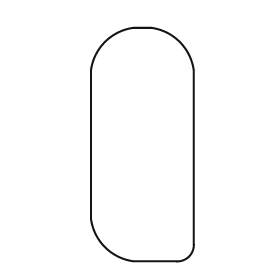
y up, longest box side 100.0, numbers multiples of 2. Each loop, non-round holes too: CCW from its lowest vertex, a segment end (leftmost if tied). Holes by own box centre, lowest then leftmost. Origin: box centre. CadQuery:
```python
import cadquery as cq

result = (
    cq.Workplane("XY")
    .moveTo(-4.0, -50.0)
    .lineTo(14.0, -50.0)
    .threePointArc((20.0, -48.0), (22.0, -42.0))
    .lineTo(22.0, 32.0)
    .threePointArc((16.0, 44.0), (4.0, 50.0))
    .lineTo(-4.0, 50.0)
    .threePointArc((-16.0, 44.0), (-22.0, 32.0))
    .lineTo(-22.0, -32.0)
    .threePointArc((-16.0, -44.0), (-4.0, -50.0))
    .close()
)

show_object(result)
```